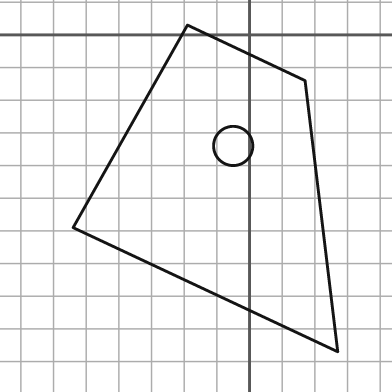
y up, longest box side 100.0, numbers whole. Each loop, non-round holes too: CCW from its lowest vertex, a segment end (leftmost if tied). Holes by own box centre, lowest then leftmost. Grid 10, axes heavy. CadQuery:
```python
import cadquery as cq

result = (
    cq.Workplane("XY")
    .moveTo(27.0, -97.0)
    .lineTo(17.0, -14.0)
    .lineTo(-19.0, 3.0)
    .lineTo(-54.0, -59.0)
    .close()
    .moveTo(-5.0, -34.0)
    .circle(6.0)
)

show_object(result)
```